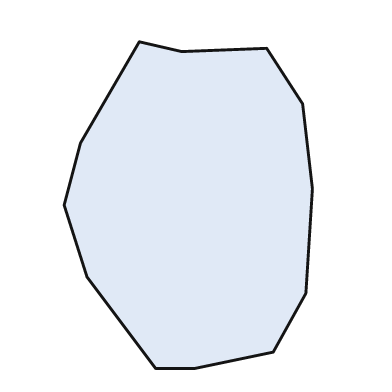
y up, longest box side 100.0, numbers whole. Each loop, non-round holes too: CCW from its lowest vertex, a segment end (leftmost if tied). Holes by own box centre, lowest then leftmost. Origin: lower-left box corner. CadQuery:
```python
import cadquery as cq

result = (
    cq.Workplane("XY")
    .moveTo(28.0, 0.0)
    .lineTo(40.0, 0.0)
    .lineTo(64.0, 5.0)
    .lineTo(74.0, 23.0)
    .lineTo(76.0, 55.0)
    .lineTo(73.0, 81.0)
    .lineTo(62.0, 98.0)
    .lineTo(36.0, 97.0)
    .lineTo(23.0, 100.0)
    .lineTo(5.0, 69.0)
    .lineTo(0.0, 50.0)
    .lineTo(7.0, 28.0)
    .close()
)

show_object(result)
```